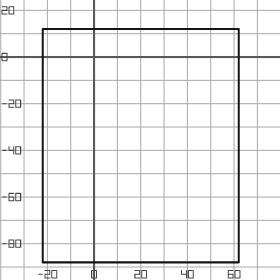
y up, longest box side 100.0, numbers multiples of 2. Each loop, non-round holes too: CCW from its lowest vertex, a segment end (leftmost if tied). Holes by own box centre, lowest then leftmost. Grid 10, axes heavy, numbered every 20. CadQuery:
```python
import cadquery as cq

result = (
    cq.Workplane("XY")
    .moveTo(-22.0, -88.0)
    .lineTo(62.0, -88.0)
    .lineTo(62.0, 12.0)
    .lineTo(-22.0, 12.0)
    .close()
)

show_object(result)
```